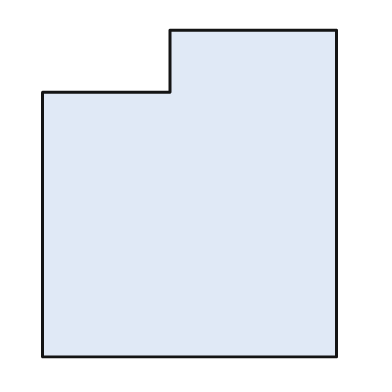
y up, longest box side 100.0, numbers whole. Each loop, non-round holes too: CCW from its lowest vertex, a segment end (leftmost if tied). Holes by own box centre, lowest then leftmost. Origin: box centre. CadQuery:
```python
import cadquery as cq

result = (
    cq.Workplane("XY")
    .moveTo(-45.0, -50.0)
    .lineTo(45.0, -50.0)
    .lineTo(45.0, 50.0)
    .lineTo(-6.0, 50.0)
    .lineTo(-6.0, 31.0)
    .lineTo(-45.0, 31.0)
    .close()
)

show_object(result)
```